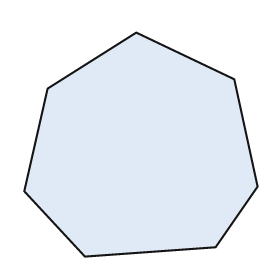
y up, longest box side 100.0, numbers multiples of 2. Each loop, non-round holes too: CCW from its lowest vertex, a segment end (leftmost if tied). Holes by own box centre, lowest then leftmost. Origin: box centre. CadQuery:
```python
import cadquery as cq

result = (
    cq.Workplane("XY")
    .moveTo(-24.0, -48.0)
    .lineTo(32.0, -44.0)
    .lineTo(50.0, -18.0)
    .lineTo(40.0, 28.0)
    .lineTo(-2.0, 48.0)
    .lineTo(-40.0, 24.0)
    .lineTo(-50.0, -20.0)
    .close()
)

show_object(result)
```